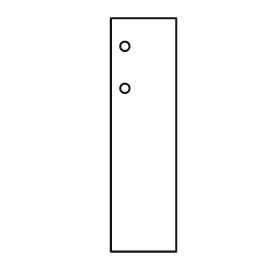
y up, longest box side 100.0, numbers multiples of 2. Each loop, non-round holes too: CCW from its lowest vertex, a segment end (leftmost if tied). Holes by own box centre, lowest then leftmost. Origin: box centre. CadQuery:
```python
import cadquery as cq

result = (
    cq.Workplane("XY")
    .moveTo(-14.0, -50.0)
    .lineTo(14.0, -50.0)
    .lineTo(14.0, 50.0)
    .lineTo(-14.0, 50.0)
    .close()
    .moveTo(-8.0, 20.0)
    .circle(2.0)
    .moveTo(-8.0, 38.0)
    .circle(2.0)
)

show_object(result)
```